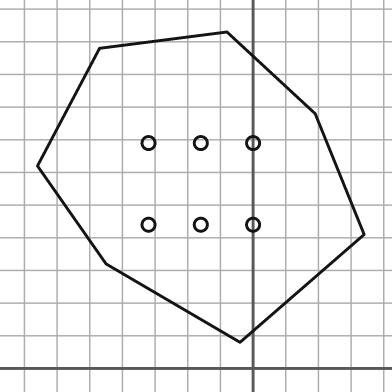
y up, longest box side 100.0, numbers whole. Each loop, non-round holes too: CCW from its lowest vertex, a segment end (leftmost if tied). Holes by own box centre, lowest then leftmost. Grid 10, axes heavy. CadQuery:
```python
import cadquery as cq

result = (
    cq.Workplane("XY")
    .moveTo(-4.0, 8.0)
    .lineTo(34.0, 41.0)
    .lineTo(19.0, 78.0)
    .lineTo(-8.0, 103.0)
    .lineTo(-47.0, 98.0)
    .lineTo(-66.0, 62.0)
    .lineTo(-45.0, 32.0)
    .close()
    .moveTo(-32.0, 44.0)
    .circle(2.0)
    .moveTo(-16.0, 44.0)
    .circle(2.0)
    .moveTo(0.0, 44.0)
    .circle(2.0)
    .moveTo(-32.0, 69.0)
    .circle(2.0)
    .moveTo(-16.0, 69.0)
    .circle(2.0)
    .moveTo(0.0, 69.0)
    .circle(2.0)
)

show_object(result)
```